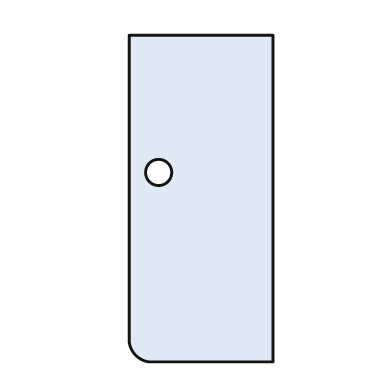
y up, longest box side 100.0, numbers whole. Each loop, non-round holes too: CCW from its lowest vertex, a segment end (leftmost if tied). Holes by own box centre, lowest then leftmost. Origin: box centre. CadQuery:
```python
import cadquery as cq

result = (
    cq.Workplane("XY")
    .moveTo(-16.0, -50.0)
    .lineTo(22.0, -50.0)
    .lineTo(22.0, 50.0)
    .lineTo(-22.0, 50.0)
    .lineTo(-22.0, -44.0)
    .threePointArc((-20.0, -48.0), (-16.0, -50.0))
    .close()
    .moveTo(-13.0, 8.0)
    .circle(4.0)
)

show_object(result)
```